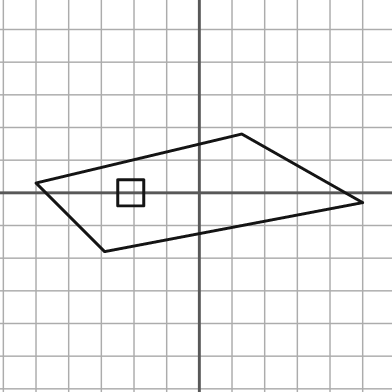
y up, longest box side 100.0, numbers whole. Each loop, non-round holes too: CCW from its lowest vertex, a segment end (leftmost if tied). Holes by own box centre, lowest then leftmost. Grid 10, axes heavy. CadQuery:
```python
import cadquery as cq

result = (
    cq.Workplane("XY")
    .moveTo(-29.0, -18.0)
    .lineTo(50.0, -3.0)
    .lineTo(13.0, 18.0)
    .lineTo(-50.0, 3.0)
    .close()
    .moveTo(-25.0, -4.0)
    .lineTo(-17.0, -4.0)
    .lineTo(-17.0, 4.0)
    .lineTo(-25.0, 4.0)
    .close()
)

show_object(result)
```